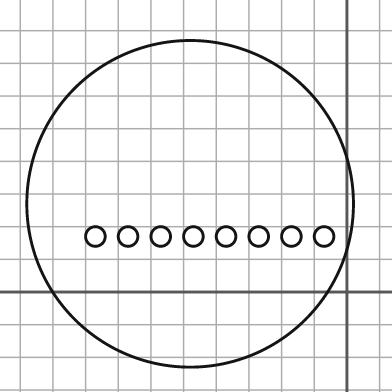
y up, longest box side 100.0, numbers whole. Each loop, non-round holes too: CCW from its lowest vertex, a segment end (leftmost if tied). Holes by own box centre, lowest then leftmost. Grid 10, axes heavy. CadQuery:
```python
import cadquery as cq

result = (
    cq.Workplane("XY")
    .moveTo(-48.0, 27.0)
    .circle(50.0)
    .moveTo(-77.0, 17.0)
    .circle(3.0)
    .moveTo(-67.0, 17.0)
    .circle(3.0)
    .moveTo(-57.0, 17.0)
    .circle(3.0)
    .moveTo(-47.0, 17.0)
    .circle(3.0)
    .moveTo(-37.0, 17.0)
    .circle(3.0)
    .moveTo(-27.0, 17.0)
    .circle(3.0)
    .moveTo(-17.0, 17.0)
    .circle(3.0)
    .moveTo(-7.0, 17.0)
    .circle(3.0)
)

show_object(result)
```